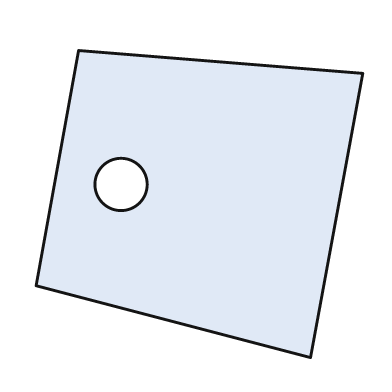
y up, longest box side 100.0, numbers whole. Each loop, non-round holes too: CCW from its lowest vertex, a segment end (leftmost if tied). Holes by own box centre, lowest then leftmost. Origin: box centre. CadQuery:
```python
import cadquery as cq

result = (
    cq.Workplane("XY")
    .moveTo(34.0, -47.0)
    .lineTo(50.0, 40.0)
    .lineTo(-37.0, 47.0)
    .lineTo(-50.0, -25.0)
    .close()
    .moveTo(-24.0, 6.0)
    .circle(8.0)
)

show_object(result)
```